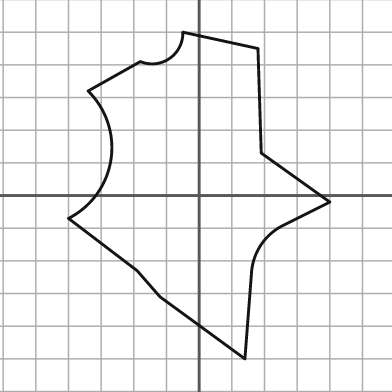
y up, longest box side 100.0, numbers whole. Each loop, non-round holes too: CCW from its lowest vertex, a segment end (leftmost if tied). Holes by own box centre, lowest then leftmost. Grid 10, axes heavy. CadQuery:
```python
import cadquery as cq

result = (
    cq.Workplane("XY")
    .moveTo(14.0, -50.0)
    .lineTo(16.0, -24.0)
    .threePointArc((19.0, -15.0), (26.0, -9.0))
    .lineTo(40.0, -2.0)
    .lineTo(19.0, 13.0)
    .lineTo(18.0, 45.0)
    .lineTo(-5.0, 50.0)
    .threePointArc((-9.0, 42.0), (-18.0, 41.0))
    .lineTo(-34.0, 32.0)
    .threePointArc((-27.0, 11.0), (-40.0, -7.0))
    .lineTo(-19.0, -23.0)
    .lineTo(-12.0, -31.0)
    .close()
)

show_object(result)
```